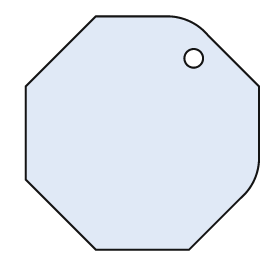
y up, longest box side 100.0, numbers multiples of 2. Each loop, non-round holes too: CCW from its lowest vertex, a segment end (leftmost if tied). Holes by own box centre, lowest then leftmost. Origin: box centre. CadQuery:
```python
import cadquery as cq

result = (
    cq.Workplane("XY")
    .moveTo(-20.0, -50.0)
    .lineTo(20.0, -50.0)
    .lineTo(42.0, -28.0)
    .threePointArc((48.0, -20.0), (50.0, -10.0))
    .lineTo(50.0, 20.0)
    .lineTo(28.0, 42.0)
    .threePointArc((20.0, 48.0), (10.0, 50.0))
    .lineTo(-20.0, 50.0)
    .lineTo(-50.0, 20.0)
    .lineTo(-50.0, -20.0)
    .close()
    .moveTo(22.0, 32.0)
    .circle(4.0)
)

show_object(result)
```